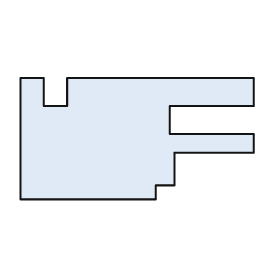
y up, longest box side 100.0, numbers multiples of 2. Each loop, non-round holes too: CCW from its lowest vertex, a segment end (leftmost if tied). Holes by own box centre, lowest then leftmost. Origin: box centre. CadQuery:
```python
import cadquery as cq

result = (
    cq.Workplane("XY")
    .moveTo(-50.0, -26.0)
    .lineTo(8.0, -26.0)
    .lineTo(8.0, -20.0)
    .lineTo(16.0, -20.0)
    .lineTo(16.0, -6.0)
    .lineTo(50.0, -6.0)
    .lineTo(50.0, 2.0)
    .lineTo(14.0, 2.0)
    .lineTo(14.0, 14.0)
    .lineTo(50.0, 14.0)
    .lineTo(50.0, 26.0)
    .lineTo(-30.0, 26.0)
    .lineTo(-30.0, 14.0)
    .lineTo(-40.0, 14.0)
    .lineTo(-40.0, 26.0)
    .lineTo(-50.0, 26.0)
    .close()
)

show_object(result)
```